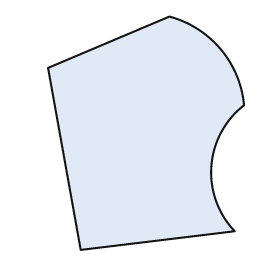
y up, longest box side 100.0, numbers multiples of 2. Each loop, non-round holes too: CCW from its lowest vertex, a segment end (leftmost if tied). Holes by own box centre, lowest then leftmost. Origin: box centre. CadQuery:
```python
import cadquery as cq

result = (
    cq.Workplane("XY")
    .moveTo(-28.0, -50.0)
    .lineTo(38.0, -42.0)
    .threePointArc((28.0, -14.0), (42.0, 12.0))
    .threePointArc((32.0, 36.0), (10.0, 50.0))
    .lineTo(-42.0, 28.0)
    .close()
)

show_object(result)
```